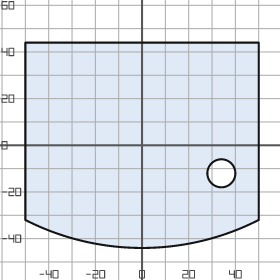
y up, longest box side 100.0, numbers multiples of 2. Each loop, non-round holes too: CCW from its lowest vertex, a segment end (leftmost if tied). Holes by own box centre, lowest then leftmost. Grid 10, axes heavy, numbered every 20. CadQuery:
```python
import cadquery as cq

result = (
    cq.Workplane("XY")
    .moveTo(-50.0, -32.0)
    .threePointArc((0.0, -44.0), (50.0, -32.0))
    .lineTo(50.0, 44.0)
    .lineTo(-50.0, 44.0)
    .close()
    .moveTo(34.0, -12.0)
    .circle(6.0)
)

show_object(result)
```